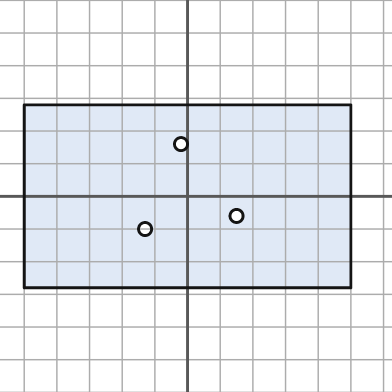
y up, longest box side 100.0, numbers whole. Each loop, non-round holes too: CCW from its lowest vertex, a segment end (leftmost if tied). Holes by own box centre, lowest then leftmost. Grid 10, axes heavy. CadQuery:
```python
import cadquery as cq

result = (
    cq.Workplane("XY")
    .moveTo(-50.0, -28.0)
    .lineTo(50.0, -28.0)
    .lineTo(50.0, 28.0)
    .lineTo(-50.0, 28.0)
    .close()
    .moveTo(-13.0, -10.0)
    .circle(2.0)
    .moveTo(15.0, -6.0)
    .circle(2.0)
    .moveTo(-2.0, 16.0)
    .circle(2.0)
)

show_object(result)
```